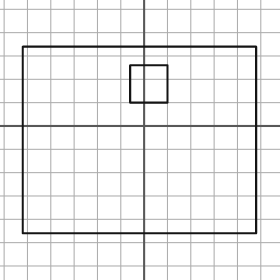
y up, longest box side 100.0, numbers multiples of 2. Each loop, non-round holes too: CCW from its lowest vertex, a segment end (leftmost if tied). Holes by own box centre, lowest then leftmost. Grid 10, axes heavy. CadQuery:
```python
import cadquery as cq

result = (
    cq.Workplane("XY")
    .moveTo(-52.0, -46.0)
    .lineTo(48.0, -46.0)
    .lineTo(48.0, 34.0)
    .lineTo(-52.0, 34.0)
    .close()
    .moveTo(-6.0, 10.0)
    .lineTo(10.0, 10.0)
    .lineTo(10.0, 26.0)
    .lineTo(-6.0, 26.0)
    .close()
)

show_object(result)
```